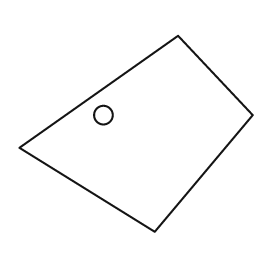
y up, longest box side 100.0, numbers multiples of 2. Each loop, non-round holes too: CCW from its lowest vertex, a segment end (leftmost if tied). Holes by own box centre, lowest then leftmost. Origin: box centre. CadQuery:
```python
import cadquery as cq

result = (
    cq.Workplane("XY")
    .moveTo(8.0, -42.0)
    .lineTo(50.0, 8.0)
    .lineTo(18.0, 42.0)
    .lineTo(-50.0, -6.0)
    .close()
    .moveTo(-14.0, 8.0)
    .circle(4.0)
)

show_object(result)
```